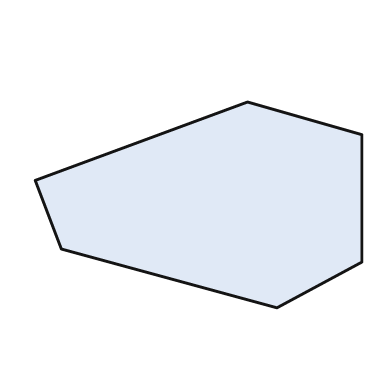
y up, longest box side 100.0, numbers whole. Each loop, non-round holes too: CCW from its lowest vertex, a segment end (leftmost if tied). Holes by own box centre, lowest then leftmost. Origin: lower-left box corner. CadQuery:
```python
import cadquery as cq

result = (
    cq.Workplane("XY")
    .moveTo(74.0, 0.0)
    .lineTo(100.0, 14.0)
    .lineTo(100.0, 53.0)
    .lineTo(65.0, 63.0)
    .lineTo(0.0, 39.0)
    .lineTo(8.0, 18.0)
    .close()
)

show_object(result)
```